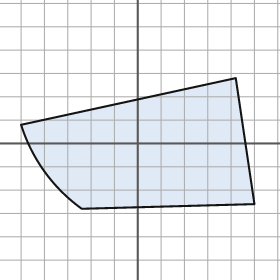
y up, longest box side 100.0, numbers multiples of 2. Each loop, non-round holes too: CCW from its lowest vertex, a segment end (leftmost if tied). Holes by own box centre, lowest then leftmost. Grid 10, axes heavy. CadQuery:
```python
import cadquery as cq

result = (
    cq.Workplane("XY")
    .moveTo(-24.0, -28.0)
    .lineTo(50.0, -26.0)
    .lineTo(42.0, 28.0)
    .lineTo(-50.0, 8.0)
    .threePointArc((-40.0, -12.0), (-24.0, -28.0))
    .close()
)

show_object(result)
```